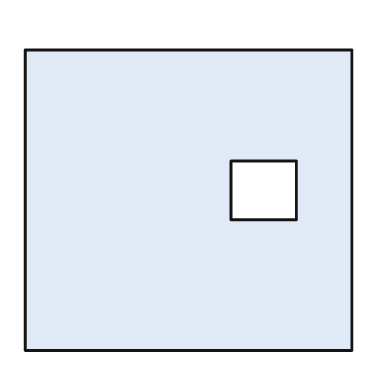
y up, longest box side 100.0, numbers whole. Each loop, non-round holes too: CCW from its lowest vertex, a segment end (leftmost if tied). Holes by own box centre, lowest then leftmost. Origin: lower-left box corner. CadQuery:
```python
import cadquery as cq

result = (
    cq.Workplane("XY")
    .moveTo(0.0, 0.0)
    .lineTo(100.0, 0.0)
    .lineTo(100.0, 92.0)
    .lineTo(0.0, 92.0)
    .close()
    .moveTo(63.0, 40.0)
    .lineTo(83.0, 40.0)
    .lineTo(83.0, 58.0)
    .lineTo(63.0, 58.0)
    .close()
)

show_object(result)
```